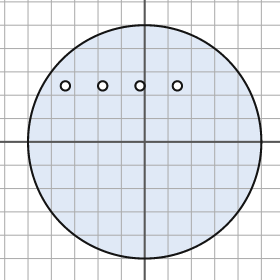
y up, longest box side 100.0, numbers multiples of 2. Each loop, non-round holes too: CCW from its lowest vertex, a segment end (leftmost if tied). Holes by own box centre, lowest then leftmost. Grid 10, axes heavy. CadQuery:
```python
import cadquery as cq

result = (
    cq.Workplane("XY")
    .moveTo(0.0, 0.0)
    .circle(50.0)
    .moveTo(-34.0, 24.0)
    .circle(2.0)
    .moveTo(-18.0, 24.0)
    .circle(2.0)
    .moveTo(-2.0, 24.0)
    .circle(2.0)
    .moveTo(14.0, 24.0)
    .circle(2.0)
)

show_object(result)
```